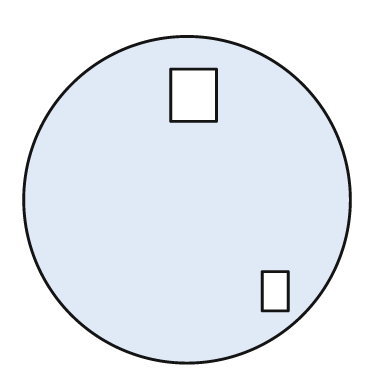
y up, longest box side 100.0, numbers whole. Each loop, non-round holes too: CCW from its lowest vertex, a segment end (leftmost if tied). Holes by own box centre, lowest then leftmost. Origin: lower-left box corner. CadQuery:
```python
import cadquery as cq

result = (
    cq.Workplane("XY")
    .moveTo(50.0, 50.0)
    .circle(50.0)
    .moveTo(73.0, 16.0)
    .lineTo(81.0, 16.0)
    .lineTo(81.0, 28.0)
    .lineTo(73.0, 28.0)
    .close()
    .moveTo(45.0, 74.0)
    .lineTo(59.0, 74.0)
    .lineTo(59.0, 90.0)
    .lineTo(45.0, 90.0)
    .close()
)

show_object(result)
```